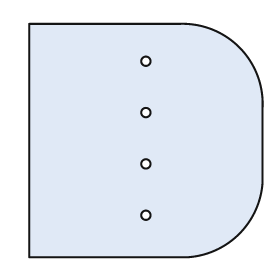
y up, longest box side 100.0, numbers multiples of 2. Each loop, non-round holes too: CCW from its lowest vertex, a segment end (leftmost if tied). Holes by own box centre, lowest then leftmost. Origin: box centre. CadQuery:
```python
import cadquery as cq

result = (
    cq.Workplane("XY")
    .moveTo(-50.0, -50.0)
    .lineTo(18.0, -50.0)
    .threePointArc((40.0, -40.0), (50.0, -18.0))
    .lineTo(50.0, 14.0)
    .threePointArc((40.0, 40.0), (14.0, 50.0))
    .lineTo(-50.0, 50.0)
    .close()
    .moveTo(0.0, -32.0)
    .circle(2.0)
    .moveTo(0.0, -10.0)
    .circle(2.0)
    .moveTo(0.0, 12.0)
    .circle(2.0)
    .moveTo(0.0, 34.0)
    .circle(2.0)
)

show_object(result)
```